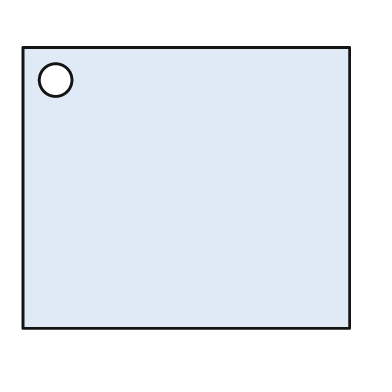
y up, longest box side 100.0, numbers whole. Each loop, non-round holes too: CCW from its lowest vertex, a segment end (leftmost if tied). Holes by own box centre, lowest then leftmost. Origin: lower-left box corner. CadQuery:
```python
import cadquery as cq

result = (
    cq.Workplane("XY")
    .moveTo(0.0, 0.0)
    .lineTo(100.0, 0.0)
    .lineTo(100.0, 86.0)
    .lineTo(0.0, 86.0)
    .close()
    .moveTo(10.0, 76.0)
    .circle(5.0)
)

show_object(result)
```